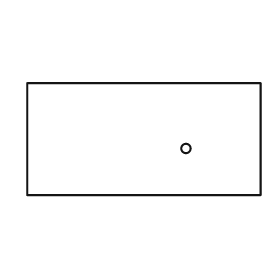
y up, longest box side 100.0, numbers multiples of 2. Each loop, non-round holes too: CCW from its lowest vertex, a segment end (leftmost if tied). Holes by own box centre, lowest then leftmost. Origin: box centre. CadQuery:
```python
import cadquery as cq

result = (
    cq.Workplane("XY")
    .moveTo(-50.0, -24.0)
    .lineTo(50.0, -24.0)
    .lineTo(50.0, 24.0)
    .lineTo(-50.0, 24.0)
    .close()
    .moveTo(18.0, -4.0)
    .circle(2.0)
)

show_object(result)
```